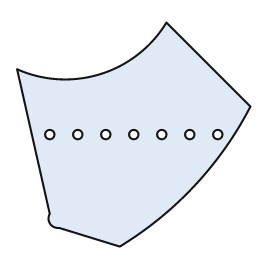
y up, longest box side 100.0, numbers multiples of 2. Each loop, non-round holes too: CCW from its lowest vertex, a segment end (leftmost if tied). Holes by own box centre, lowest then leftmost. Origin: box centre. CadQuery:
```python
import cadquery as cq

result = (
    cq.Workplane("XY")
    .moveTo(-6.0, -48.0)
    .threePointArc((26.0, -22.0), (50.0, 12.0))
    .lineTo(14.0, 48.0)
    .threePointArc((-14.0, 26.0), (-50.0, 28.0))
    .lineTo(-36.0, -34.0)
    .threePointArc((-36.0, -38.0), (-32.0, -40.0))
    .close()
    .moveTo(-36.0, 0.0)
    .circle(2.0)
    .moveTo(-24.0, 0.0)
    .circle(2.0)
    .moveTo(-12.0, 0.0)
    .circle(2.0)
    .moveTo(0.0, 0.0)
    .circle(2.0)
    .moveTo(12.0, 0.0)
    .circle(2.0)
    .moveTo(24.0, 0.0)
    .circle(2.0)
    .moveTo(36.0, 0.0)
    .circle(2.0)
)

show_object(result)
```